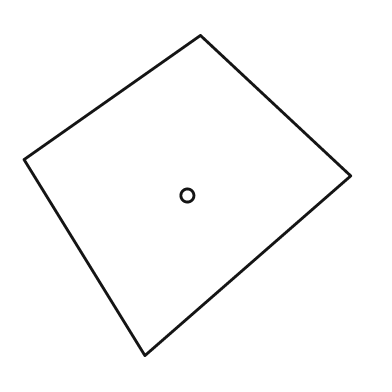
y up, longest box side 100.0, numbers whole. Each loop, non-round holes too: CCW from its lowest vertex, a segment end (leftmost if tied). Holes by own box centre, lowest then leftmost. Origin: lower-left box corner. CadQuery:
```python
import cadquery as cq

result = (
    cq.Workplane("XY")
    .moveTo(37.0, 0.0)
    .lineTo(100.0, 55.0)
    .lineTo(54.0, 98.0)
    .lineTo(0.0, 60.0)
    .close()
    .moveTo(50.0, 49.0)
    .circle(2.0)
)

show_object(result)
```